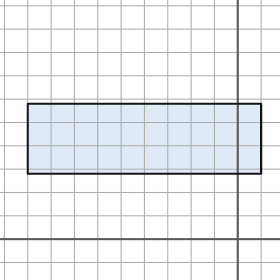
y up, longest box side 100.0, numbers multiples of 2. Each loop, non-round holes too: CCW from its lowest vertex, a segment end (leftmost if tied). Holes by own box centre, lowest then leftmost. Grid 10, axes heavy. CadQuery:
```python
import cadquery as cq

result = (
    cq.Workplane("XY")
    .moveTo(-90.0, 28.0)
    .lineTo(10.0, 28.0)
    .lineTo(10.0, 58.0)
    .lineTo(-90.0, 58.0)
    .close()
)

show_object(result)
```